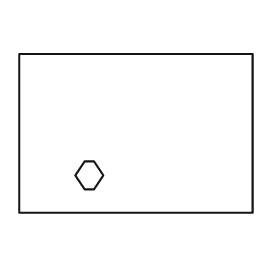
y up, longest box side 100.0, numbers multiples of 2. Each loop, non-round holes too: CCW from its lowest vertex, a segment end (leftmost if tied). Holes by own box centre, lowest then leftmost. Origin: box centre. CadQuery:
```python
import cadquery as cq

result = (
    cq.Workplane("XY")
    .moveTo(-50.0, -34.0)
    .lineTo(50.0, -34.0)
    .lineTo(50.0, 34.0)
    .lineTo(-50.0, 34.0)
    .close()
    .moveTo(-22.0, -24.0)
    .lineTo(-18.0, -24.0)
    .lineTo(-14.0, -18.0)
    .lineTo(-18.0, -12.0)
    .lineTo(-22.0, -12.0)
    .lineTo(-26.0, -18.0)
    .close()
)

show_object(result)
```